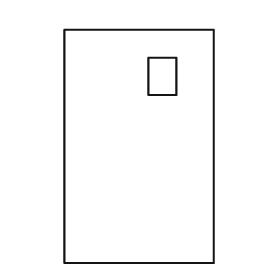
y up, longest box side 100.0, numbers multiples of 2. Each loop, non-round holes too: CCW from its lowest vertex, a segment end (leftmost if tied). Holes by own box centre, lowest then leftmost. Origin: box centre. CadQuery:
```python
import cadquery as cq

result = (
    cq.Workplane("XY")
    .moveTo(-32.0, -50.0)
    .lineTo(32.0, -50.0)
    .lineTo(32.0, 50.0)
    .lineTo(-32.0, 50.0)
    .close()
    .moveTo(4.0, 22.0)
    .lineTo(16.0, 22.0)
    .lineTo(16.0, 38.0)
    .lineTo(4.0, 38.0)
    .close()
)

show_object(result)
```